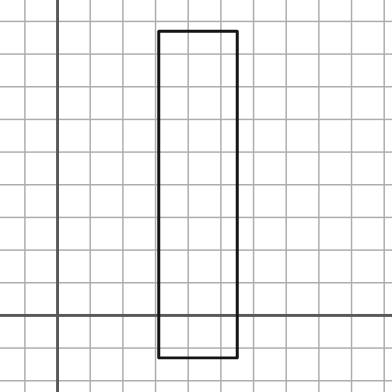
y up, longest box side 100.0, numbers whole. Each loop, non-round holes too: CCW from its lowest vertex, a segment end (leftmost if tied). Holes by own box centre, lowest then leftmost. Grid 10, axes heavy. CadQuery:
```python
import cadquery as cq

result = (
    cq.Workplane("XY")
    .moveTo(31.0, -13.0)
    .lineTo(55.0, -13.0)
    .lineTo(55.0, 87.0)
    .lineTo(31.0, 87.0)
    .close()
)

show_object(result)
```